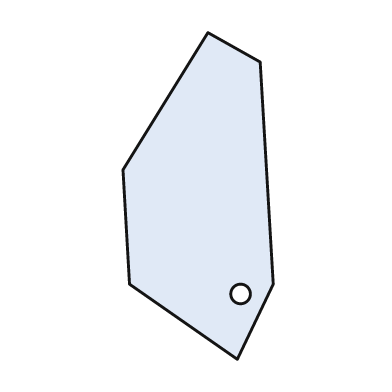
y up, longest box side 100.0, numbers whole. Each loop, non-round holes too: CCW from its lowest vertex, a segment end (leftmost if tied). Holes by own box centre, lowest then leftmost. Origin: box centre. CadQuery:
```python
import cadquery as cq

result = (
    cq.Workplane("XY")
    .moveTo(12.0, -50.0)
    .lineTo(23.0, -27.0)
    .lineTo(19.0, 41.0)
    .lineTo(3.0, 50.0)
    .lineTo(-23.0, 8.0)
    .lineTo(-21.0, -27.0)
    .close()
    .moveTo(13.0, -30.0)
    .circle(3.0)
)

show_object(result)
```